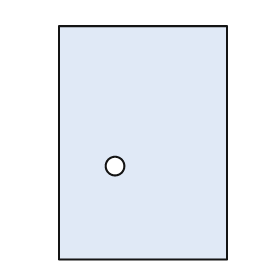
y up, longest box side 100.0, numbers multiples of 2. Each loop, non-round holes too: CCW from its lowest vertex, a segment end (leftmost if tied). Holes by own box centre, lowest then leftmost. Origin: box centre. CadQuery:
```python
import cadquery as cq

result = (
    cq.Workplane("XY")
    .moveTo(-36.0, -50.0)
    .lineTo(36.0, -50.0)
    .lineTo(36.0, 50.0)
    .lineTo(-36.0, 50.0)
    .close()
    .moveTo(-12.0, -10.0)
    .circle(4.0)
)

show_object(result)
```